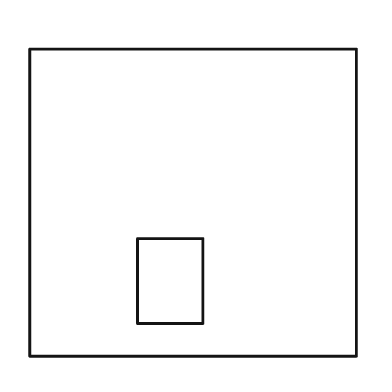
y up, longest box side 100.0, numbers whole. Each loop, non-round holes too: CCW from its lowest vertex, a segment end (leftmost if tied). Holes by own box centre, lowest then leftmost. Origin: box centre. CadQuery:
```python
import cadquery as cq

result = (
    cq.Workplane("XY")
    .moveTo(-50.0, -47.0)
    .lineTo(50.0, -47.0)
    .lineTo(50.0, 47.0)
    .lineTo(-50.0, 47.0)
    .close()
    .moveTo(-17.0, -37.0)
    .lineTo(3.0, -37.0)
    .lineTo(3.0, -11.0)
    .lineTo(-17.0, -11.0)
    .close()
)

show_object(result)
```